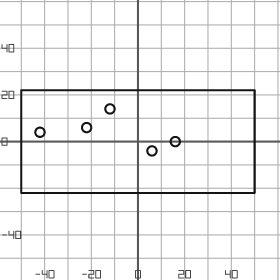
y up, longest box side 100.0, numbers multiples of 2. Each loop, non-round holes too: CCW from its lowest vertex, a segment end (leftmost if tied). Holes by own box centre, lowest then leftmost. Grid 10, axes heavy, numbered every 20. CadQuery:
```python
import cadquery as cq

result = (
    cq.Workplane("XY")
    .moveTo(-50.0, -22.0)
    .lineTo(50.0, -22.0)
    .lineTo(50.0, 22.0)
    .lineTo(-50.0, 22.0)
    .close()
    .moveTo(6.0, -4.0)
    .circle(2.0)
    .moveTo(16.0, 0.0)
    .circle(2.0)
    .moveTo(-42.0, 4.0)
    .circle(2.0)
    .moveTo(-22.0, 6.0)
    .circle(2.0)
    .moveTo(-12.0, 14.0)
    .circle(2.0)
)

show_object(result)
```